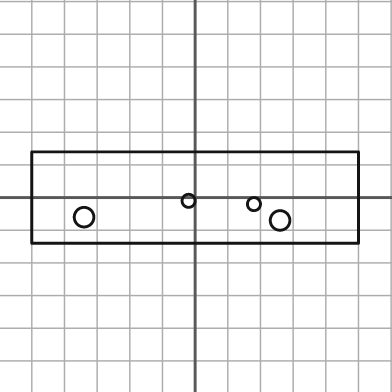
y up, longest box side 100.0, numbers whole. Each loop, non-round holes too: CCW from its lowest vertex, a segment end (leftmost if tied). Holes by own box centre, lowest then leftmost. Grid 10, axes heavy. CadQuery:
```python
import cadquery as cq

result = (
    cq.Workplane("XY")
    .moveTo(-50.0, -14.0)
    .lineTo(50.0, -14.0)
    .lineTo(50.0, 14.0)
    .lineTo(-50.0, 14.0)
    .close()
    .moveTo(26.0, -7.0)
    .circle(3.0)
    .moveTo(-34.0, -6.0)
    .circle(3.0)
    .moveTo(18.0, -2.0)
    .circle(2.0)
    .moveTo(-2.0, -1.0)
    .circle(2.0)
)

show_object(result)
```